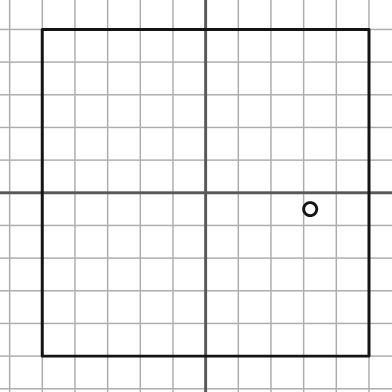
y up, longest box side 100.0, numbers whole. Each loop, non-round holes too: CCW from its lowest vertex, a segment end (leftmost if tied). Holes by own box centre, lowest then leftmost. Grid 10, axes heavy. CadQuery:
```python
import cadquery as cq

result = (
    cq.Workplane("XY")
    .moveTo(-50.0, -50.0)
    .lineTo(50.0, -50.0)
    .lineTo(50.0, 50.0)
    .lineTo(-50.0, 50.0)
    .close()
    .moveTo(32.0, -5.0)
    .circle(2.0)
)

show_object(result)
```